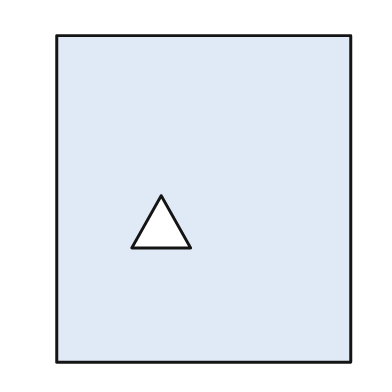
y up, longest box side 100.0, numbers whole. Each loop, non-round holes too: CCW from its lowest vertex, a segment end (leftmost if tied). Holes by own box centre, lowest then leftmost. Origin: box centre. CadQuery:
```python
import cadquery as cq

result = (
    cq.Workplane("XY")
    .moveTo(-45.0, -50.0)
    .lineTo(45.0, -50.0)
    .lineTo(45.0, 50.0)
    .lineTo(-45.0, 50.0)
    .close()
    .moveTo(-22.0, -15.0)
    .lineTo(-4.0, -15.0)
    .lineTo(-13.0, 1.0)
    .close()
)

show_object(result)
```